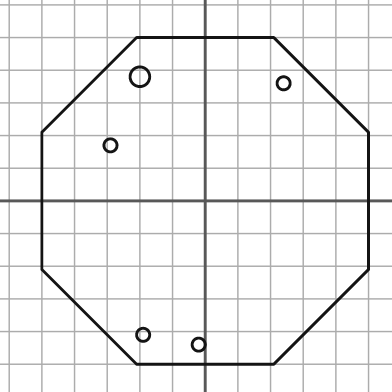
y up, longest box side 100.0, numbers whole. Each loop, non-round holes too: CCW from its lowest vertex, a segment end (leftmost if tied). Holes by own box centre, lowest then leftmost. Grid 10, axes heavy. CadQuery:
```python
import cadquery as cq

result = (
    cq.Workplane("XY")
    .moveTo(-21.0, -50.0)
    .lineTo(21.0, -50.0)
    .lineTo(50.0, -21.0)
    .lineTo(50.0, 21.0)
    .lineTo(21.0, 50.0)
    .lineTo(-21.0, 50.0)
    .lineTo(-50.0, 21.0)
    .lineTo(-50.0, -21.0)
    .close()
    .moveTo(-2.0, -44.0)
    .circle(2.0)
    .moveTo(-19.0, -41.0)
    .circle(2.0)
    .moveTo(-29.0, 17.0)
    .circle(2.0)
    .moveTo(24.0, 36.0)
    .circle(2.0)
    .moveTo(-20.0, 38.0)
    .circle(3.0)
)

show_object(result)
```